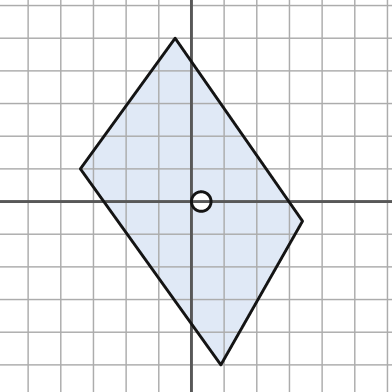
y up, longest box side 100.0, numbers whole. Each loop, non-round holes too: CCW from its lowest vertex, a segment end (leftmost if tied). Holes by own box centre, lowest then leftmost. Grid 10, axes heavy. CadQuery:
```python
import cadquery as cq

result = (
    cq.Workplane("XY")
    .moveTo(9.0, -50.0)
    .lineTo(34.0, -6.0)
    .lineTo(-5.0, 50.0)
    .lineTo(-34.0, 10.0)
    .close()
    .moveTo(3.0, 0.0)
    .circle(3.0)
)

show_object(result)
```